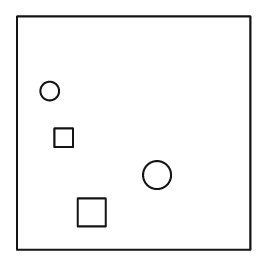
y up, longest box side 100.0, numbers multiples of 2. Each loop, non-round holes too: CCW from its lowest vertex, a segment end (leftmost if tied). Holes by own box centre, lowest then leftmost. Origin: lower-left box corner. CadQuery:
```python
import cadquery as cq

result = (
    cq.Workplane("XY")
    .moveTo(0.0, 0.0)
    .lineTo(100.0, 0.0)
    .lineTo(100.0, 100.0)
    .lineTo(0.0, 100.0)
    .close()
    .moveTo(26.0, 10.0)
    .lineTo(38.0, 10.0)
    .lineTo(38.0, 22.0)
    .lineTo(26.0, 22.0)
    .close()
    .moveTo(60.0, 32.0)
    .circle(6.0)
    .moveTo(16.0, 44.0)
    .lineTo(24.0, 44.0)
    .lineTo(24.0, 52.0)
    .lineTo(16.0, 52.0)
    .close()
    .moveTo(14.0, 68.0)
    .circle(4.0)
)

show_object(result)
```